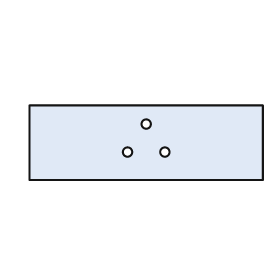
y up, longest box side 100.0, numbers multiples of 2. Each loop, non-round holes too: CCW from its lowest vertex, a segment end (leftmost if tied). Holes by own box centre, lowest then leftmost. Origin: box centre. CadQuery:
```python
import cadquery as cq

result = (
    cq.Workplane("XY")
    .moveTo(-50.0, -16.0)
    .lineTo(50.0, -16.0)
    .lineTo(50.0, 16.0)
    .lineTo(-50.0, 16.0)
    .close()
    .moveTo(-8.0, -4.0)
    .circle(2.0)
    .moveTo(8.0, -4.0)
    .circle(2.0)
    .moveTo(0.0, 8.0)
    .circle(2.0)
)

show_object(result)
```